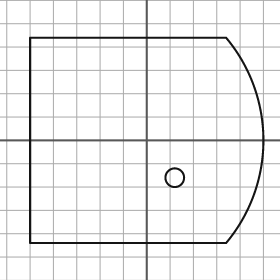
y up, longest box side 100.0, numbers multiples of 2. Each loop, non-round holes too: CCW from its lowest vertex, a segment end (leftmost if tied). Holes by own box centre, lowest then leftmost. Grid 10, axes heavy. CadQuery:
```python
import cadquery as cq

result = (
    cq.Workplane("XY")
    .moveTo(-50.0, -44.0)
    .lineTo(34.0, -44.0)
    .threePointArc((50.0, 0.0), (34.0, 44.0))
    .lineTo(-50.0, 44.0)
    .close()
    .moveTo(12.0, -16.0)
    .circle(4.0)
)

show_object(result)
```